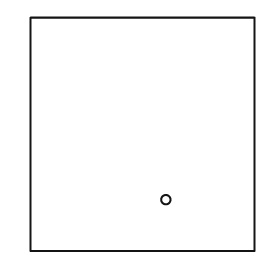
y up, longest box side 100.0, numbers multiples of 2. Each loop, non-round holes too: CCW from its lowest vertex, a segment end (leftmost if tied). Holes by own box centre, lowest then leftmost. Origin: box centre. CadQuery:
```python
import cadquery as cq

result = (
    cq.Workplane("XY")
    .moveTo(-48.0, -50.0)
    .lineTo(48.0, -50.0)
    .lineTo(48.0, 50.0)
    .lineTo(-48.0, 50.0)
    .close()
    .moveTo(10.0, -28.0)
    .circle(2.0)
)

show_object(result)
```